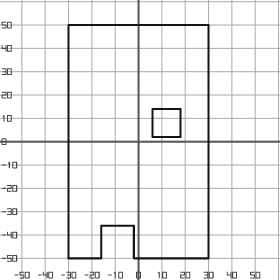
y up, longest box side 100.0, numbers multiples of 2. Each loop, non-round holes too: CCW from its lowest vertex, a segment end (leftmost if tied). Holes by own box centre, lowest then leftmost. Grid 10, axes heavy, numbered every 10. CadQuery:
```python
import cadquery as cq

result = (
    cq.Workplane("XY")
    .moveTo(-30.0, -50.0)
    .lineTo(-16.0, -50.0)
    .lineTo(-16.0, -36.0)
    .lineTo(-2.0, -36.0)
    .lineTo(-2.0, -50.0)
    .lineTo(30.0, -50.0)
    .lineTo(30.0, 50.0)
    .lineTo(-30.0, 50.0)
    .close()
    .moveTo(6.0, 2.0)
    .lineTo(18.0, 2.0)
    .lineTo(18.0, 14.0)
    .lineTo(6.0, 14.0)
    .close()
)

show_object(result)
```